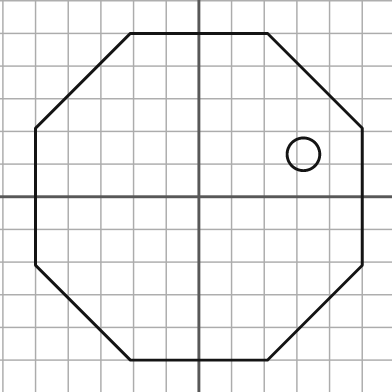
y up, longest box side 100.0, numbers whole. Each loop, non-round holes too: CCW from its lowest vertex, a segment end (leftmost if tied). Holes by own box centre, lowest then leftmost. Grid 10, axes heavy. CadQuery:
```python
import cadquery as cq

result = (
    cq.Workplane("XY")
    .moveTo(-21.0, -50.0)
    .lineTo(21.0, -50.0)
    .lineTo(50.0, -21.0)
    .lineTo(50.0, 21.0)
    .lineTo(21.0, 50.0)
    .lineTo(-21.0, 50.0)
    .lineTo(-50.0, 21.0)
    .lineTo(-50.0, -21.0)
    .close()
    .moveTo(32.0, 13.0)
    .circle(5.0)
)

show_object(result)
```